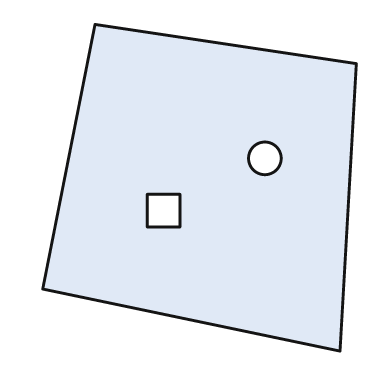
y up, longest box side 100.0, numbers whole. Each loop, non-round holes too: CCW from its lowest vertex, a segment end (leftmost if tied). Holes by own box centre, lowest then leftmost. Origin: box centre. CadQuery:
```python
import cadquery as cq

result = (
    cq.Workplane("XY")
    .moveTo(43.0, -50.0)
    .lineTo(48.0, 38.0)
    .lineTo(-32.0, 50.0)
    .lineTo(-48.0, -31.0)
    .close()
    .moveTo(-16.0, -12.0)
    .lineTo(-6.0, -12.0)
    .lineTo(-6.0, -2.0)
    .lineTo(-16.0, -2.0)
    .close()
    .moveTo(20.0, 9.0)
    .circle(5.0)
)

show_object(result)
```